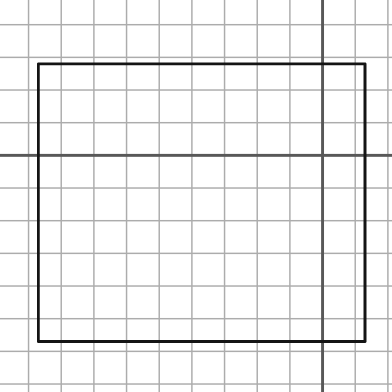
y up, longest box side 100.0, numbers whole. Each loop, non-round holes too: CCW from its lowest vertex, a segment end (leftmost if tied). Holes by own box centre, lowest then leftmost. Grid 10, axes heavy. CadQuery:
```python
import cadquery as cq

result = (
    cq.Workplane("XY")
    .moveTo(-87.0, -57.0)
    .lineTo(13.0, -57.0)
    .lineTo(13.0, 28.0)
    .lineTo(-87.0, 28.0)
    .close()
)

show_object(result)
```